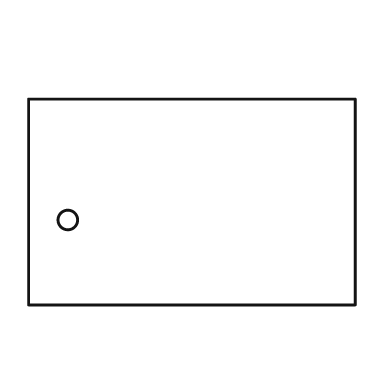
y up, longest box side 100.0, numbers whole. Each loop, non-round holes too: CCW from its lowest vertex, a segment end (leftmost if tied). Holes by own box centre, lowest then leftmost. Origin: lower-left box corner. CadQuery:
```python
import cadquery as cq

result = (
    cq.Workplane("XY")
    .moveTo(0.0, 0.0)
    .lineTo(100.0, 0.0)
    .lineTo(100.0, 63.0)
    .lineTo(0.0, 63.0)
    .close()
    .moveTo(12.0, 26.0)
    .circle(3.0)
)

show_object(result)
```